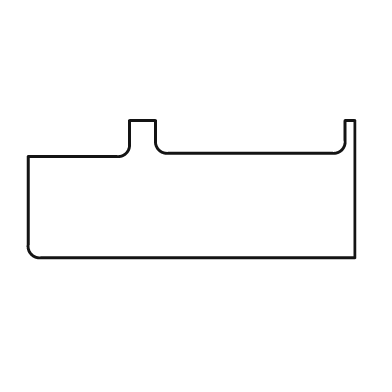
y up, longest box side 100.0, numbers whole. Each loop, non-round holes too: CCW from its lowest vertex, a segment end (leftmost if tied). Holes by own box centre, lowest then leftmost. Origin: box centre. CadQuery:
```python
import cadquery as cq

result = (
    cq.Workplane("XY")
    .moveTo(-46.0, -21.0)
    .lineTo(50.0, -21.0)
    .lineTo(50.0, 21.0)
    .lineTo(47.0, 21.0)
    .lineTo(47.0, 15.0)
    .threePointArc((46.0, 12.0), (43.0, 11.0))
    .lineTo(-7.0, 11.0)
    .threePointArc((-10.0, 12.0), (-11.0, 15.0))
    .lineTo(-11.0, 21.0)
    .lineTo(-19.0, 21.0)
    .lineTo(-19.0, 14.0)
    .threePointArc((-20.0, 11.0), (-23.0, 10.0))
    .lineTo(-50.0, 10.0)
    .lineTo(-50.0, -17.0)
    .threePointArc((-49.0, -20.0), (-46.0, -21.0))
    .close()
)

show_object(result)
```